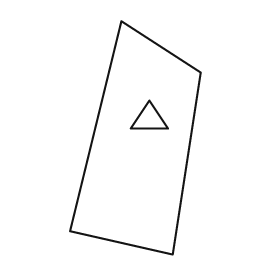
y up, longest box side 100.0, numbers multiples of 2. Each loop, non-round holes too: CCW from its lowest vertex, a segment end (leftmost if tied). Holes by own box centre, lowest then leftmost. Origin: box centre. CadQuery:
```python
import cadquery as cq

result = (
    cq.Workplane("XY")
    .moveTo(16.0, -50.0)
    .lineTo(28.0, 28.0)
    .lineTo(-6.0, 50.0)
    .lineTo(-28.0, -40.0)
    .close()
    .moveTo(-2.0, 4.0)
    .lineTo(14.0, 4.0)
    .lineTo(6.0, 16.0)
    .close()
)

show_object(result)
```